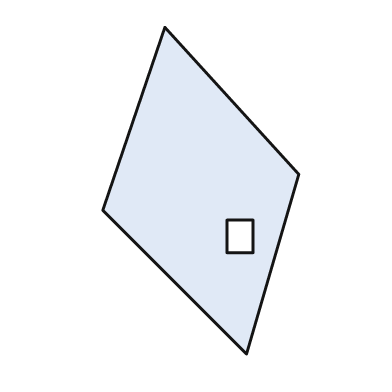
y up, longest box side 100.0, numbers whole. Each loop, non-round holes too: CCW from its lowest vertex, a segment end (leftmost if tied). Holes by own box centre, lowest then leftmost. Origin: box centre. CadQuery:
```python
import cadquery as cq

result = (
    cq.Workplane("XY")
    .moveTo(14.0, -50.0)
    .lineTo(30.0, 5.0)
    .lineTo(-11.0, 50.0)
    .lineTo(-30.0, -6.0)
    .close()
    .moveTo(8.0, -19.0)
    .lineTo(16.0, -19.0)
    .lineTo(16.0, -9.0)
    .lineTo(8.0, -9.0)
    .close()
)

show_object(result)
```